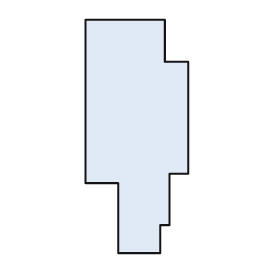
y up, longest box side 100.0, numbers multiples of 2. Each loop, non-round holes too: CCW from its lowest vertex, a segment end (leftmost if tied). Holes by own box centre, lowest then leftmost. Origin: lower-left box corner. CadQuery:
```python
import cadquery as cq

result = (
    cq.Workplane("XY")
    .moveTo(14.0, 0.0)
    .lineTo(32.0, 0.0)
    .lineTo(32.0, 12.0)
    .lineTo(36.0, 12.0)
    .lineTo(36.0, 34.0)
    .lineTo(44.0, 34.0)
    .lineTo(44.0, 82.0)
    .lineTo(34.0, 82.0)
    .lineTo(34.0, 100.0)
    .lineTo(0.0, 100.0)
    .lineTo(0.0, 30.0)
    .lineTo(14.0, 30.0)
    .close()
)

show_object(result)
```